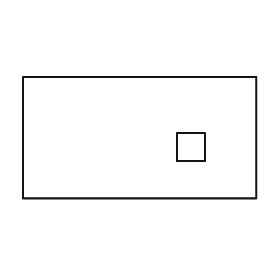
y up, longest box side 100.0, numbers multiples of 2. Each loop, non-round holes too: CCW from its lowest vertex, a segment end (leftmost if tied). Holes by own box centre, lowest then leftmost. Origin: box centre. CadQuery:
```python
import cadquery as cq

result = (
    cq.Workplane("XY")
    .moveTo(-50.0, -26.0)
    .lineTo(50.0, -26.0)
    .lineTo(50.0, 26.0)
    .lineTo(-50.0, 26.0)
    .close()
    .moveTo(16.0, -10.0)
    .lineTo(28.0, -10.0)
    .lineTo(28.0, 2.0)
    .lineTo(16.0, 2.0)
    .close()
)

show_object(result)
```